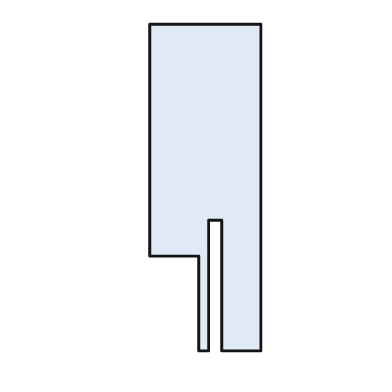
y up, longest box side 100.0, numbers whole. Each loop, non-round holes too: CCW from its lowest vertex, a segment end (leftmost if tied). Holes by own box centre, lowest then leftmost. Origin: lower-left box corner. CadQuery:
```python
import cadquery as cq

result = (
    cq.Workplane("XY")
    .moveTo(15.0, 0.0)
    .lineTo(18.0, 0.0)
    .lineTo(18.0, 40.0)
    .lineTo(22.0, 40.0)
    .lineTo(22.0, 0.0)
    .lineTo(34.0, 0.0)
    .lineTo(34.0, 100.0)
    .lineTo(0.0, 100.0)
    .lineTo(0.0, 29.0)
    .lineTo(15.0, 29.0)
    .close()
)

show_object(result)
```